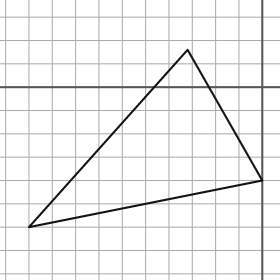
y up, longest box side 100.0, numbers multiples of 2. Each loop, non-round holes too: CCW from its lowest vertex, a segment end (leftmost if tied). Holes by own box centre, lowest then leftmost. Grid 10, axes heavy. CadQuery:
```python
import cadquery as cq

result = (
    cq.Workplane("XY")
    .moveTo(-100.0, -60.0)
    .lineTo(0.0, -40.0)
    .lineTo(-32.0, 16.0)
    .close()
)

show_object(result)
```